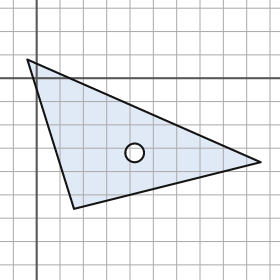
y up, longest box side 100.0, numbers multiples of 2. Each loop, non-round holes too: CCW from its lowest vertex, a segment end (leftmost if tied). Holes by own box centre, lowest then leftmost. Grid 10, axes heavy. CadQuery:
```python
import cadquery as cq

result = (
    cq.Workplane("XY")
    .moveTo(16.0, -56.0)
    .lineTo(96.0, -36.0)
    .lineTo(-4.0, 8.0)
    .close()
    .moveTo(42.0, -32.0)
    .circle(4.0)
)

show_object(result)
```